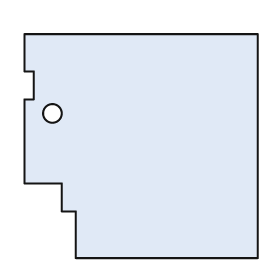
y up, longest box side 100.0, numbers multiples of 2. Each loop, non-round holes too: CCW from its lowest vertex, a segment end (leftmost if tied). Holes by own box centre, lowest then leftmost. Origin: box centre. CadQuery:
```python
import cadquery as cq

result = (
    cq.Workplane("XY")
    .moveTo(-28.0, -48.0)
    .lineTo(50.0, -48.0)
    .lineTo(50.0, 48.0)
    .lineTo(-50.0, 48.0)
    .lineTo(-50.0, 32.0)
    .lineTo(-46.0, 32.0)
    .lineTo(-46.0, 20.0)
    .lineTo(-50.0, 20.0)
    .lineTo(-50.0, -16.0)
    .lineTo(-34.0, -16.0)
    .lineTo(-34.0, -28.0)
    .lineTo(-28.0, -28.0)
    .close()
    .moveTo(-38.0, 14.0)
    .circle(4.0)
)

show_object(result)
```